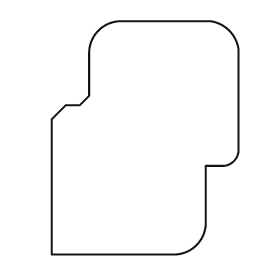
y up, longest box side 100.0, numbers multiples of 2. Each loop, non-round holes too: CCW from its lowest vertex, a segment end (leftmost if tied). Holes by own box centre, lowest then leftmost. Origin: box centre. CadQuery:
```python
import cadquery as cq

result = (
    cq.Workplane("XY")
    .moveTo(-40.0, -50.0)
    .lineTo(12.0, -50.0)
    .threePointArc((22.0, -46.0), (26.0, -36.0))
    .lineTo(26.0, -12.0)
    .lineTo(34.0, -12.0)
    .threePointArc((38.0, -10.0), (40.0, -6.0))
    .lineTo(40.0, 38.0)
    .threePointArc((36.0, 46.0), (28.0, 50.0))
    .lineTo(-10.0, 50.0)
    .threePointArc((-20.0, 46.0), (-24.0, 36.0))
    .lineTo(-24.0, 18.0)
    .lineTo(-28.0, 14.0)
    .lineTo(-34.0, 14.0)
    .lineTo(-40.0, 8.0)
    .close()
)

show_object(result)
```